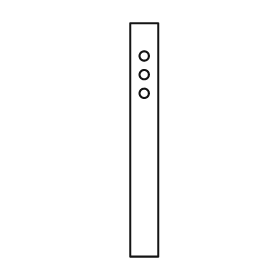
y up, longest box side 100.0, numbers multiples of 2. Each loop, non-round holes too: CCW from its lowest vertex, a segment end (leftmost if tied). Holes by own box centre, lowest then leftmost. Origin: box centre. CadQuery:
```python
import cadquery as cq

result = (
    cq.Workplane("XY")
    .moveTo(-6.0, -50.0)
    .lineTo(6.0, -50.0)
    .lineTo(6.0, 50.0)
    .lineTo(-6.0, 50.0)
    .close()
    .moveTo(0.0, 20.0)
    .circle(2.0)
    .moveTo(0.0, 28.0)
    .circle(2.0)
    .moveTo(0.0, 36.0)
    .circle(2.0)
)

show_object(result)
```